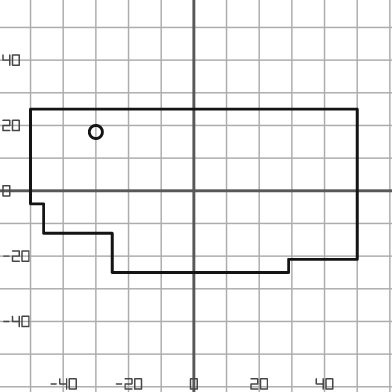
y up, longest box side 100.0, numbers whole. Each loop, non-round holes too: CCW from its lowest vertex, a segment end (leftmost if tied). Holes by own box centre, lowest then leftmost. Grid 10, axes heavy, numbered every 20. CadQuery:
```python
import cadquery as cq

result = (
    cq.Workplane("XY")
    .moveTo(-25.0, -25.0)
    .lineTo(29.0, -25.0)
    .lineTo(29.0, -21.0)
    .lineTo(50.0, -21.0)
    .lineTo(50.0, 25.0)
    .lineTo(-50.0, 25.0)
    .lineTo(-50.0, -4.0)
    .lineTo(-46.0, -4.0)
    .lineTo(-46.0, -13.0)
    .lineTo(-25.0, -13.0)
    .close()
    .moveTo(-30.0, 18.0)
    .circle(2.0)
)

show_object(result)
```